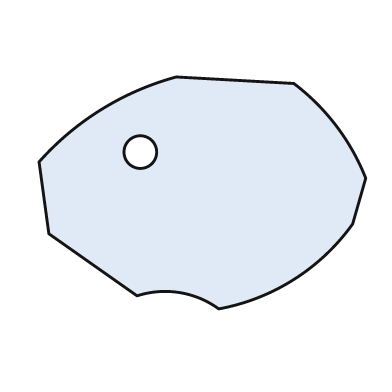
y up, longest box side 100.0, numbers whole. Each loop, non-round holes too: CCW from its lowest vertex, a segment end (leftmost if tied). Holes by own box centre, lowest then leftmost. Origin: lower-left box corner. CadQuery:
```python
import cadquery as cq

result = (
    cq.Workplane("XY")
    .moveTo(55.0, 0.0)
    .threePointArc((78.0, 9.0), (96.0, 26.0))
    .lineTo(100.0, 40.0)
    .threePointArc((91.0, 56.0), (78.0, 69.0))
    .lineTo(42.0, 71.0)
    .threePointArc((19.0, 61.0), (0.0, 45.0))
    .lineTo(3.0, 23.0)
    .lineTo(30.0, 4.0)
    .threePointArc((43.0, 5.0), (55.0, 0.0))
    .close()
    .moveTo(31.0, 48.0)
    .circle(5.0)
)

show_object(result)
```